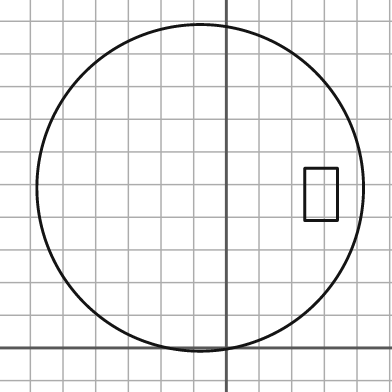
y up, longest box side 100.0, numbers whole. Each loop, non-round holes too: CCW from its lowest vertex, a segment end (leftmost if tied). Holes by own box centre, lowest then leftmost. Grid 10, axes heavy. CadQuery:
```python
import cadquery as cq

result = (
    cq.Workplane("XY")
    .moveTo(-8.0, 49.0)
    .circle(50.0)
    .moveTo(24.0, 39.0)
    .lineTo(34.0, 39.0)
    .lineTo(34.0, 55.0)
    .lineTo(24.0, 55.0)
    .close()
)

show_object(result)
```